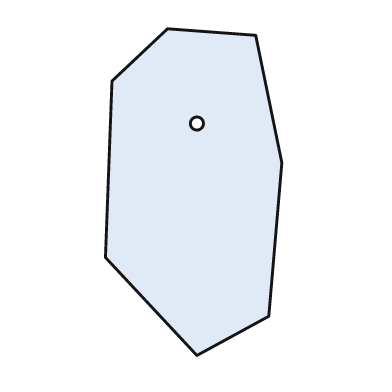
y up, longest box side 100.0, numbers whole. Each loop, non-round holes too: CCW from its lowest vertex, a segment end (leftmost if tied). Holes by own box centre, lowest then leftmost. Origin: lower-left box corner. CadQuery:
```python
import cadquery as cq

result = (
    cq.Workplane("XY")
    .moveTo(28.0, 0.0)
    .lineTo(50.0, 12.0)
    .lineTo(54.0, 59.0)
    .lineTo(46.0, 98.0)
    .lineTo(19.0, 100.0)
    .lineTo(2.0, 84.0)
    .lineTo(0.0, 30.0)
    .close()
    .moveTo(28.0, 71.0)
    .circle(2.0)
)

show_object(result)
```